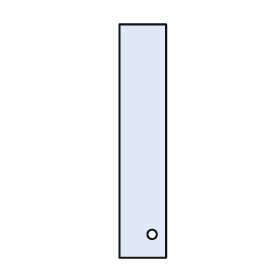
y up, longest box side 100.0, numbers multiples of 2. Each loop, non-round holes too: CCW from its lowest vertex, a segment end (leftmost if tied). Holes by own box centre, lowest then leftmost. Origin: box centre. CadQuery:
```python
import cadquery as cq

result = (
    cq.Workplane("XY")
    .moveTo(-10.0, -50.0)
    .lineTo(10.0, -50.0)
    .lineTo(10.0, 50.0)
    .lineTo(-10.0, 50.0)
    .close()
    .moveTo(4.0, -40.0)
    .circle(2.0)
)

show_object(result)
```